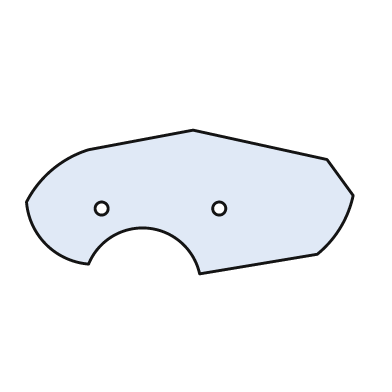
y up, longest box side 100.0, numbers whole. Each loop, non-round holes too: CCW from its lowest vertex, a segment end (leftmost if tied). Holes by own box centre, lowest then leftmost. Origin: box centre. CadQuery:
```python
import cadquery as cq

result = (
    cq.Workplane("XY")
    .moveTo(3.0, -22.0)
    .lineTo(39.0, -16.0)
    .threePointArc((46.0, -8.0), (50.0, 2.0))
    .lineTo(42.0, 13.0)
    .lineTo(1.0, 22.0)
    .lineTo(-31.0, 16.0)
    .threePointArc((-42.0, 10.0), (-50.0, 0.0))
    .threePointArc((-44.0, -13.0), (-31.0, -19.0))
    .threePointArc((-13.0, -8.0), (3.0, -22.0))
    .close()
    .moveTo(-27.0, -2.0)
    .circle(2.0)
    .moveTo(9.0, -2.0)
    .circle(2.0)
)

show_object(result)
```